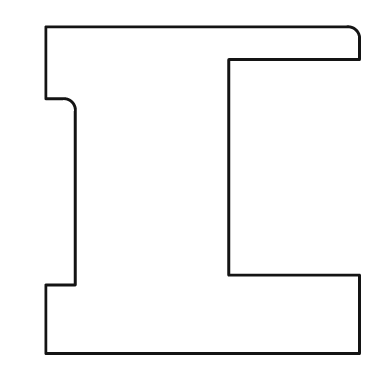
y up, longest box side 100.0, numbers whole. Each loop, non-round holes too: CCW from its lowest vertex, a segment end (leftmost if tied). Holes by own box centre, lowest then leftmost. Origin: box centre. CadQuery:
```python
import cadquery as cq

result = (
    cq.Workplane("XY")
    .moveTo(-48.0, -50.0)
    .lineTo(48.0, -50.0)
    .lineTo(48.0, -26.0)
    .lineTo(8.0, -26.0)
    .lineTo(8.0, 40.0)
    .lineTo(48.0, 40.0)
    .lineTo(48.0, 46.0)
    .threePointArc((47.0, 49.0), (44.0, 50.0))
    .lineTo(-48.0, 50.0)
    .lineTo(-48.0, 28.0)
    .lineTo(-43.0, 28.0)
    .threePointArc((-40.0, 27.0), (-39.0, 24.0))
    .lineTo(-39.0, -29.0)
    .lineTo(-48.0, -29.0)
    .close()
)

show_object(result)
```